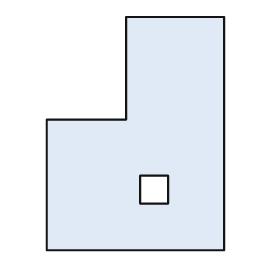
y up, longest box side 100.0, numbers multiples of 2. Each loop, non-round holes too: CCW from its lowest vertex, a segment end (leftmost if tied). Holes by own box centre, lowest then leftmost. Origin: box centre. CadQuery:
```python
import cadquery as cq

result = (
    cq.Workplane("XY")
    .moveTo(-38.0, -50.0)
    .lineTo(38.0, -50.0)
    .lineTo(38.0, 50.0)
    .lineTo(-4.0, 50.0)
    .lineTo(-4.0, 6.0)
    .lineTo(-38.0, 6.0)
    .close()
    .moveTo(2.0, -30.0)
    .lineTo(14.0, -30.0)
    .lineTo(14.0, -18.0)
    .lineTo(2.0, -18.0)
    .close()
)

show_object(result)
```